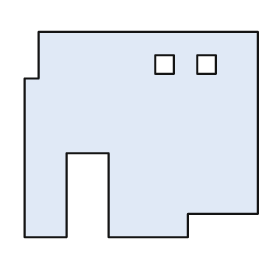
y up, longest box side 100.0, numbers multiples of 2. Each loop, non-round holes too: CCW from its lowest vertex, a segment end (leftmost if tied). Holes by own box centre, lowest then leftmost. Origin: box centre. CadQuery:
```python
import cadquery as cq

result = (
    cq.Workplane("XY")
    .moveTo(-50.0, -44.0)
    .lineTo(-32.0, -44.0)
    .lineTo(-32.0, -8.0)
    .lineTo(-14.0, -8.0)
    .lineTo(-14.0, -44.0)
    .lineTo(20.0, -44.0)
    .lineTo(20.0, -34.0)
    .lineTo(50.0, -34.0)
    .lineTo(50.0, 44.0)
    .lineTo(-44.0, 44.0)
    .lineTo(-44.0, 24.0)
    .lineTo(-50.0, 24.0)
    .close()
    .moveTo(6.0, 26.0)
    .lineTo(14.0, 26.0)
    .lineTo(14.0, 34.0)
    .lineTo(6.0, 34.0)
    .close()
    .moveTo(24.0, 26.0)
    .lineTo(32.0, 26.0)
    .lineTo(32.0, 34.0)
    .lineTo(24.0, 34.0)
    .close()
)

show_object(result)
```